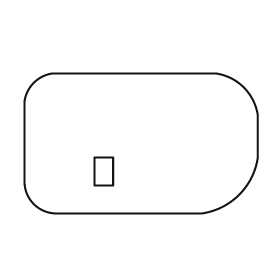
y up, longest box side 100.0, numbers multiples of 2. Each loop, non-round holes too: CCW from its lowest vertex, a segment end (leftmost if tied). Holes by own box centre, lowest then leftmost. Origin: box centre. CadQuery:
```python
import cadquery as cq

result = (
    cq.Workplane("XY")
    .moveTo(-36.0, -30.0)
    .lineTo(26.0, -30.0)
    .threePointArc((42.0, -22.0), (50.0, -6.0))
    .lineTo(50.0, 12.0)
    .threePointArc((44.0, 24.0), (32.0, 30.0))
    .lineTo(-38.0, 30.0)
    .threePointArc((-46.0, 26.0), (-50.0, 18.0))
    .lineTo(-50.0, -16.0)
    .threePointArc((-46.0, -26.0), (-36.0, -30.0))
    .close()
    .moveTo(-20.0, -18.0)
    .lineTo(-12.0, -18.0)
    .lineTo(-12.0, -6.0)
    .lineTo(-20.0, -6.0)
    .close()
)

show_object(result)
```